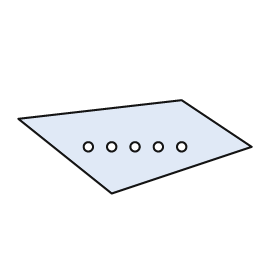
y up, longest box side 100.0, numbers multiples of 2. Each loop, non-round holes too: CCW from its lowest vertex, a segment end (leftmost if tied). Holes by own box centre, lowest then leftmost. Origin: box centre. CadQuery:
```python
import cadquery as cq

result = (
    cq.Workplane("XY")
    .moveTo(-10.0, -20.0)
    .lineTo(50.0, 0.0)
    .lineTo(20.0, 20.0)
    .lineTo(-50.0, 12.0)
    .close()
    .moveTo(-20.0, 0.0)
    .circle(2.0)
    .moveTo(-10.0, 0.0)
    .circle(2.0)
    .moveTo(0.0, 0.0)
    .circle(2.0)
    .moveTo(10.0, 0.0)
    .circle(2.0)
    .moveTo(20.0, 0.0)
    .circle(2.0)
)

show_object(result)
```